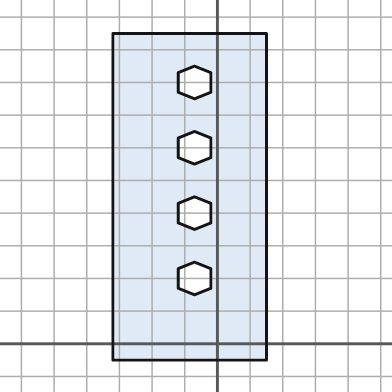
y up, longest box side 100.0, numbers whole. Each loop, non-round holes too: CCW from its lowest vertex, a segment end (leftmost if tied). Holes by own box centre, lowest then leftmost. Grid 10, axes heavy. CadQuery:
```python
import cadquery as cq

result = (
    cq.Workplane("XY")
    .moveTo(-32.0, -5.0)
    .lineTo(15.0, -5.0)
    .lineTo(15.0, 95.0)
    .lineTo(-32.0, 95.0)
    .close()
    .moveTo(-7.0, 15.0)
    .lineTo(-2.0, 17.0)
    .lineTo(-2.0, 23.0)
    .lineTo(-7.0, 25.0)
    .lineTo(-12.0, 23.0)
    .lineTo(-12.0, 17.0)
    .close()
    .moveTo(-7.0, 35.0)
    .lineTo(-2.0, 37.0)
    .lineTo(-2.0, 43.0)
    .lineTo(-7.0, 45.0)
    .lineTo(-12.0, 43.0)
    .lineTo(-12.0, 37.0)
    .close()
    .moveTo(-7.0, 55.0)
    .lineTo(-2.0, 57.0)
    .lineTo(-2.0, 63.0)
    .lineTo(-7.0, 65.0)
    .lineTo(-12.0, 63.0)
    .lineTo(-12.0, 57.0)
    .close()
    .moveTo(-7.0, 75.0)
    .lineTo(-2.0, 77.0)
    .lineTo(-2.0, 83.0)
    .lineTo(-7.0, 85.0)
    .lineTo(-12.0, 83.0)
    .lineTo(-12.0, 77.0)
    .close()
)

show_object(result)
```